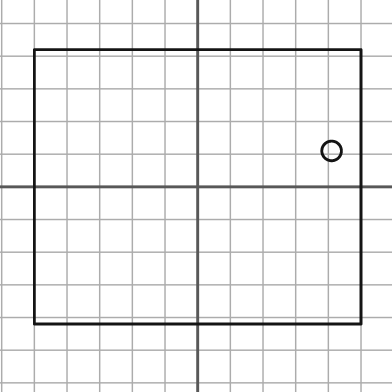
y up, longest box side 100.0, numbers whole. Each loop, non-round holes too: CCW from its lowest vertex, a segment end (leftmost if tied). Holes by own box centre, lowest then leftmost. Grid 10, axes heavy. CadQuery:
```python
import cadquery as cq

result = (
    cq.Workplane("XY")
    .moveTo(-50.0, -42.0)
    .lineTo(50.0, -42.0)
    .lineTo(50.0, 42.0)
    .lineTo(-50.0, 42.0)
    .close()
    .moveTo(41.0, 11.0)
    .circle(3.0)
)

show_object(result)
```